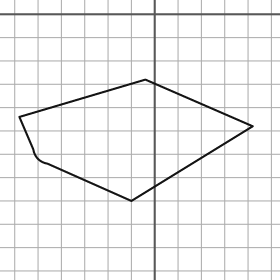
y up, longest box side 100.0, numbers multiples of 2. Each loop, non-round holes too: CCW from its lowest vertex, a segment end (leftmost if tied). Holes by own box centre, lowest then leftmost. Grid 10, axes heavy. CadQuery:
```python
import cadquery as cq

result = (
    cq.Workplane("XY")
    .moveTo(-10.0, -80.0)
    .lineTo(42.0, -48.0)
    .lineTo(-4.0, -28.0)
    .lineTo(-58.0, -44.0)
    .lineTo(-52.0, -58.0)
    .threePointArc((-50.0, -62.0), (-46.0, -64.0))
    .close()
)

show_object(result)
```